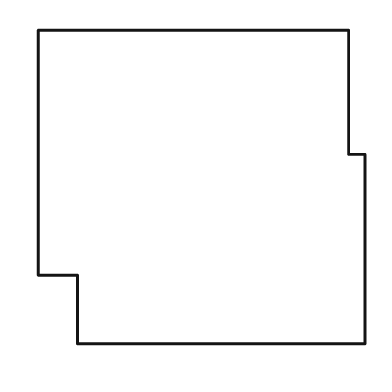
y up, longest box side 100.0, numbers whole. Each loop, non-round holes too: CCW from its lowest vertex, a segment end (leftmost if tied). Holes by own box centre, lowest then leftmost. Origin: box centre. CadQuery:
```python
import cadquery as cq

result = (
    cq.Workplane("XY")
    .moveTo(-38.0, -48.0)
    .lineTo(50.0, -48.0)
    .lineTo(50.0, 10.0)
    .lineTo(45.0, 10.0)
    .lineTo(45.0, 48.0)
    .lineTo(-50.0, 48.0)
    .lineTo(-50.0, -27.0)
    .lineTo(-38.0, -27.0)
    .close()
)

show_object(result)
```